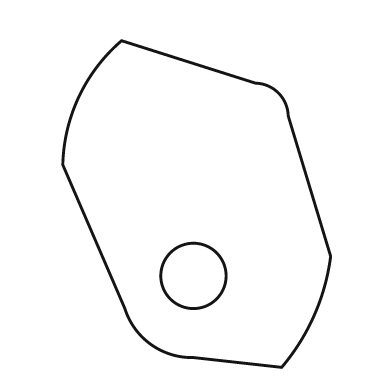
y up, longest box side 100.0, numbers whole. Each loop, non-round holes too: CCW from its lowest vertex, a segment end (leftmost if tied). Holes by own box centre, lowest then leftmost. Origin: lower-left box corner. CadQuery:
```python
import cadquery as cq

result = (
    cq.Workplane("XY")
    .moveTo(67.0, 0.0)
    .threePointArc((77.0, 16.0), (82.0, 34.0))
    .lineTo(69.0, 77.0)
    .threePointArc((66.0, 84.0), (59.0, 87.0))
    .lineTo(18.0, 100.0)
    .threePointArc((5.0, 83.0), (0.0, 62.0))
    .lineTo(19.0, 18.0)
    .threePointArc((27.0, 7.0), (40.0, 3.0))
    .close()
    .moveTo(40.0, 28.0)
    .circle(10.0)
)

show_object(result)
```